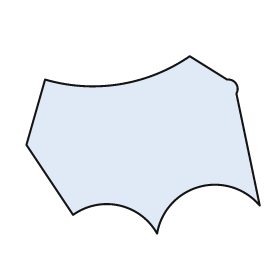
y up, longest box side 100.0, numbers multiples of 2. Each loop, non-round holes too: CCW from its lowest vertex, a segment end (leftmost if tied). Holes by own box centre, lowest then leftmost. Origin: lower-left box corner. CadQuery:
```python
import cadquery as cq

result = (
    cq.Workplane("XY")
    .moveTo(56.0, 0.0)
    .threePointArc((74.0, 20.0), (100.0, 12.0))
    .lineTo(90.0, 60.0)
    .threePointArc((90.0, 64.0), (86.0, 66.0))
    .lineTo(70.0, 76.0)
    .threePointArc((40.0, 64.0), (8.0, 66.0))
    .lineTo(0.0, 38.0)
    .lineTo(20.0, 8.0)
    .threePointArc((40.0, 12.0), (56.0, 0.0))
    .close()
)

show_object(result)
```